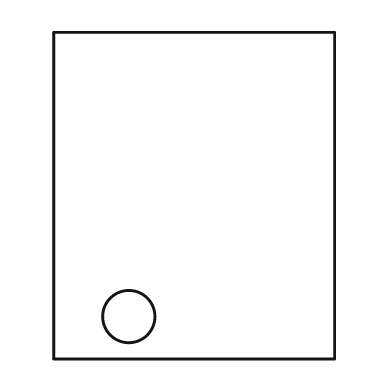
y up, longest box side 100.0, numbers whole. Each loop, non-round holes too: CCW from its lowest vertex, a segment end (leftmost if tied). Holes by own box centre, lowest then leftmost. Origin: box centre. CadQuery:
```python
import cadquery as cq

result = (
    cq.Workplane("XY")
    .moveTo(-43.0, -50.0)
    .lineTo(43.0, -50.0)
    .lineTo(43.0, 50.0)
    .lineTo(-43.0, 50.0)
    .close()
    .moveTo(-20.0, -37.0)
    .circle(8.0)
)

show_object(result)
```